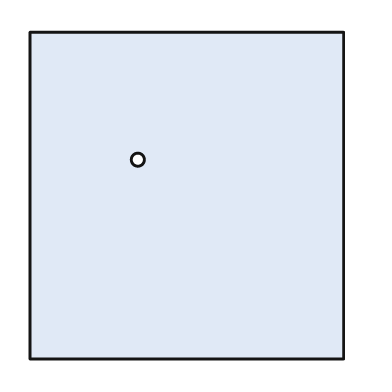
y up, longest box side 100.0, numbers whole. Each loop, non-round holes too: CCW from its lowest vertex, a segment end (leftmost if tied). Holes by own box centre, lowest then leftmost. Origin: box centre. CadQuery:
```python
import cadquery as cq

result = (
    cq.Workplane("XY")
    .moveTo(-48.0, -50.0)
    .lineTo(48.0, -50.0)
    .lineTo(48.0, 50.0)
    .lineTo(-48.0, 50.0)
    .close()
    .moveTo(-15.0, 11.0)
    .circle(2.0)
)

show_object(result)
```